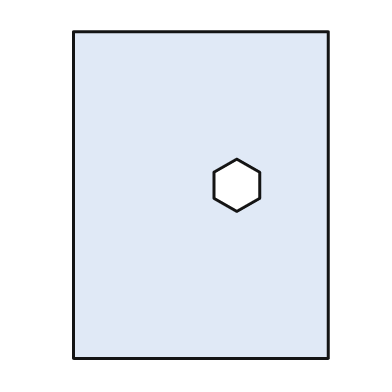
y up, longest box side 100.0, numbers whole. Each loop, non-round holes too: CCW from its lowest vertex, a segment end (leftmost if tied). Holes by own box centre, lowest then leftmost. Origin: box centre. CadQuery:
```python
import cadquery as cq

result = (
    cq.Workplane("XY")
    .moveTo(-39.0, -50.0)
    .lineTo(39.0, -50.0)
    .lineTo(39.0, 50.0)
    .lineTo(-39.0, 50.0)
    .close()
    .moveTo(11.0, -5.0)
    .lineTo(18.0, -1.0)
    .lineTo(18.0, 7.0)
    .lineTo(11.0, 11.0)
    .lineTo(4.0, 7.0)
    .lineTo(4.0, -1.0)
    .close()
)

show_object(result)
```